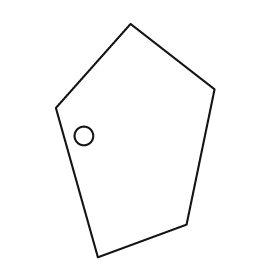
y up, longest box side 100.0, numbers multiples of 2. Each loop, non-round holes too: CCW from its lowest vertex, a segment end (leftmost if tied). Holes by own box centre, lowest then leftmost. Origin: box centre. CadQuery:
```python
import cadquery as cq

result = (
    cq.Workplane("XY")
    .moveTo(-16.0, -50.0)
    .lineTo(22.0, -36.0)
    .lineTo(34.0, 22.0)
    .lineTo(-2.0, 50.0)
    .lineTo(-34.0, 14.0)
    .close()
    .moveTo(-22.0, 2.0)
    .circle(4.0)
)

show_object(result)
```